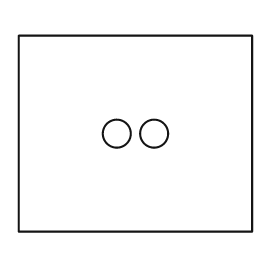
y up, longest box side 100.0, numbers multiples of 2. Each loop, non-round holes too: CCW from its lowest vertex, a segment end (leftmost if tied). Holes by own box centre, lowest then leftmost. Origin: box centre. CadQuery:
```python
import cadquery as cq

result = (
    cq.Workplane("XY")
    .moveTo(-50.0, -42.0)
    .lineTo(50.0, -42.0)
    .lineTo(50.0, 42.0)
    .lineTo(-50.0, 42.0)
    .close()
    .moveTo(-8.0, 0.0)
    .circle(6.0)
    .moveTo(8.0, 0.0)
    .circle(6.0)
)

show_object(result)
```